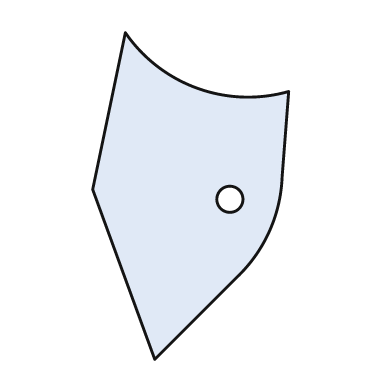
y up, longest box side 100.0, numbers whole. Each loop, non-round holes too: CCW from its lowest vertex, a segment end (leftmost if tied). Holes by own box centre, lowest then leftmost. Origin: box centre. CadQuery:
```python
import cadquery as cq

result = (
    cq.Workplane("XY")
    .moveTo(-11.0, -50.0)
    .lineTo(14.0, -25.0)
    .threePointArc((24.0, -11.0), (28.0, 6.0))
    .lineTo(30.0, 32.0)
    .threePointArc((2.0, 33.0), (-20.0, 50.0))
    .lineTo(-30.0, 2.0)
    .close()
    .moveTo(12.0, -1.0)
    .circle(4.0)
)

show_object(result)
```